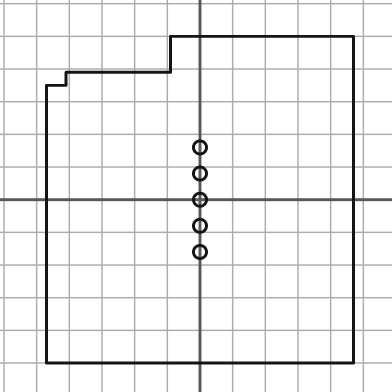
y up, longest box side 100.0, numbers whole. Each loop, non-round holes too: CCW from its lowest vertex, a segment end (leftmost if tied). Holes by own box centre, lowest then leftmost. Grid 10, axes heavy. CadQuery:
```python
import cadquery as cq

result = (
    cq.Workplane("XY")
    .moveTo(-47.0, -50.0)
    .lineTo(47.0, -50.0)
    .lineTo(47.0, 50.0)
    .lineTo(-9.0, 50.0)
    .lineTo(-9.0, 39.0)
    .lineTo(-41.0, 39.0)
    .lineTo(-41.0, 35.0)
    .lineTo(-47.0, 35.0)
    .close()
    .moveTo(0.0, -16.0)
    .circle(2.0)
    .moveTo(0.0, -8.0)
    .circle(2.0)
    .moveTo(0.0, 0.0)
    .circle(2.0)
    .moveTo(0.0, 8.0)
    .circle(2.0)
    .moveTo(0.0, 16.0)
    .circle(2.0)
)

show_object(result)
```